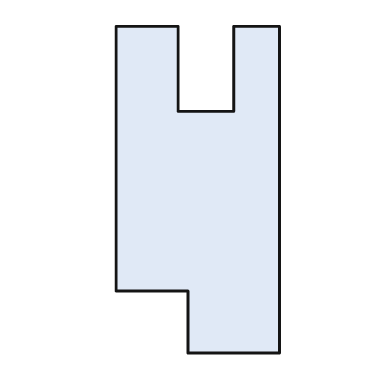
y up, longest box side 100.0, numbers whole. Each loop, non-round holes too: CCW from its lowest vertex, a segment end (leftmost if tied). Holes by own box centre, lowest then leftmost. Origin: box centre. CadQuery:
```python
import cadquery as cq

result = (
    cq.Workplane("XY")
    .moveTo(-3.0, -50.0)
    .lineTo(25.0, -50.0)
    .lineTo(25.0, 50.0)
    .lineTo(11.0, 50.0)
    .lineTo(11.0, 24.0)
    .lineTo(-6.0, 24.0)
    .lineTo(-6.0, 50.0)
    .lineTo(-25.0, 50.0)
    .lineTo(-25.0, -31.0)
    .lineTo(-3.0, -31.0)
    .close()
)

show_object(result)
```